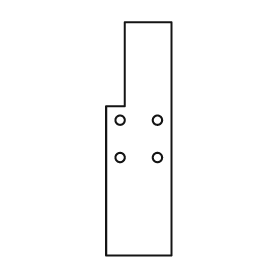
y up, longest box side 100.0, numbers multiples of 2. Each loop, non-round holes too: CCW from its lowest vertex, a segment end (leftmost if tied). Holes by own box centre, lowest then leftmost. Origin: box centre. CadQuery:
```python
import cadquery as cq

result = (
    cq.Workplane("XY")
    .moveTo(-14.0, -50.0)
    .lineTo(14.0, -50.0)
    .lineTo(14.0, 50.0)
    .lineTo(-6.0, 50.0)
    .lineTo(-6.0, 14.0)
    .lineTo(-14.0, 14.0)
    .close()
    .moveTo(-8.0, -8.0)
    .circle(2.0)
    .moveTo(8.0, -8.0)
    .circle(2.0)
    .moveTo(-8.0, 8.0)
    .circle(2.0)
    .moveTo(8.0, 8.0)
    .circle(2.0)
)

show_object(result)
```